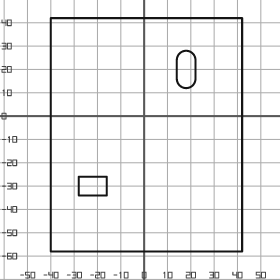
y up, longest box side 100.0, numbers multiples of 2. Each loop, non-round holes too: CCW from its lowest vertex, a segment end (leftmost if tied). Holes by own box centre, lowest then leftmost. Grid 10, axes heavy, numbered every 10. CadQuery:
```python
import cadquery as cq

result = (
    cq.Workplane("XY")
    .moveTo(-40.0, -58.0)
    .lineTo(42.0, -58.0)
    .lineTo(42.0, 42.0)
    .lineTo(-40.0, 42.0)
    .close()
    .moveTo(-28.0, -34.0)
    .lineTo(-16.0, -34.0)
    .lineTo(-16.0, -26.0)
    .lineTo(-28.0, -26.0)
    .close()
    .moveTo(14.0, 16.0)
    .threePointArc((18.0, 12.0), (22.0, 16.0))
    .lineTo(22.0, 24.0)
    .threePointArc((18.0, 28.0), (14.0, 24.0))
    .close()
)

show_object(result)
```